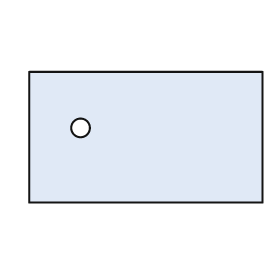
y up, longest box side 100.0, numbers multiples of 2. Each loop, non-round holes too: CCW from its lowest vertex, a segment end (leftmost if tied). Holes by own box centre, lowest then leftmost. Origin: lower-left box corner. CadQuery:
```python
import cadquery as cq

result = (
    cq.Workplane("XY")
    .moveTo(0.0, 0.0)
    .lineTo(100.0, 0.0)
    .lineTo(100.0, 56.0)
    .lineTo(0.0, 56.0)
    .close()
    .moveTo(22.0, 32.0)
    .circle(4.0)
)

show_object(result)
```